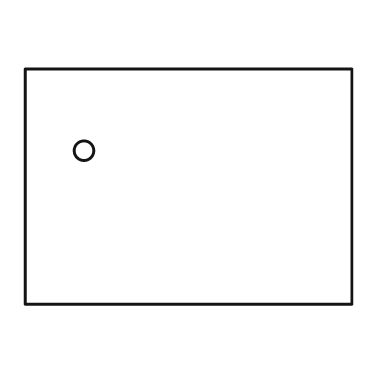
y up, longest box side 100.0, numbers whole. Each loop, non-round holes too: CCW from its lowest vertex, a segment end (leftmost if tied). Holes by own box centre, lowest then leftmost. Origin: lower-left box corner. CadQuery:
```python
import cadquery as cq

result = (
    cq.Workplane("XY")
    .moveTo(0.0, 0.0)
    .lineTo(100.0, 0.0)
    .lineTo(100.0, 72.0)
    .lineTo(0.0, 72.0)
    .close()
    .moveTo(18.0, 47.0)
    .circle(3.0)
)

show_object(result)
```